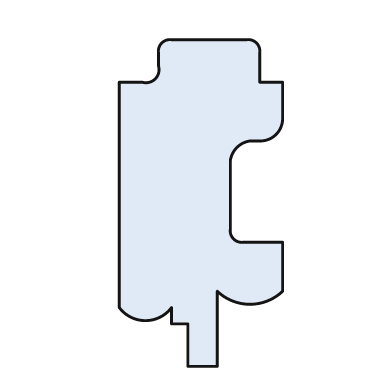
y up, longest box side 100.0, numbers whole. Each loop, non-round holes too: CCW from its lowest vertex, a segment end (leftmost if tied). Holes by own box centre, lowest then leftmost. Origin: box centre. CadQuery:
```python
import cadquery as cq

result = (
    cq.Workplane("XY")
    .moveTo(-4.0, -50.0)
    .lineTo(5.0, -50.0)
    .lineTo(5.0, -27.0)
    .threePointArc((15.0, -31.0), (25.0, -27.0))
    .lineTo(25.0, -12.0)
    .lineTo(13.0, -12.0)
    .threePointArc((10.0, -11.0), (9.0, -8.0))
    .lineTo(9.0, 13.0)
    .threePointArc((11.0, 17.0), (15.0, 19.0))
    .lineTo(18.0, 19.0)
    .threePointArc((23.0, 21.0), (25.0, 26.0))
    .lineTo(25.0, 37.0)
    .lineTo(18.0, 37.0)
    .lineTo(18.0, 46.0)
    .threePointArc((17.0, 49.0), (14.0, 50.0))
    .lineTo(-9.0, 50.0)
    .threePointArc((-12.0, 49.0), (-13.0, 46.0))
    .lineTo(-13.0, 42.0)
    .threePointArc((-14.0, 38.0), (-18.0, 37.0))
    .lineTo(-25.0, 37.0)
    .lineTo(-25.0, -32.0)
    .threePointArc((-17.0, -36.0), (-9.0, -32.0))
    .lineTo(-9.0, -37.0)
    .lineTo(-4.0, -37.0)
    .close()
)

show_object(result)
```